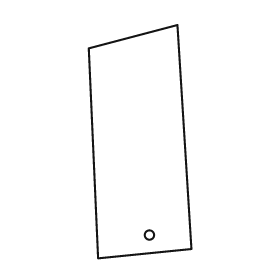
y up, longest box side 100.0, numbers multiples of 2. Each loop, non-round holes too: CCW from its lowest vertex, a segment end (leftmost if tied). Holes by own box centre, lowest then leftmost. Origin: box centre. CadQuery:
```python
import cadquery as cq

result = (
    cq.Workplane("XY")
    .moveTo(-18.0, -50.0)
    .lineTo(22.0, -46.0)
    .lineTo(16.0, 50.0)
    .lineTo(-22.0, 40.0)
    .close()
    .moveTo(4.0, -40.0)
    .circle(2.0)
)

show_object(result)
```